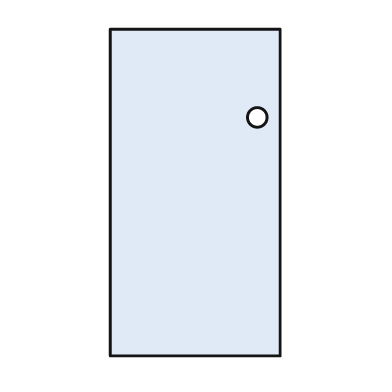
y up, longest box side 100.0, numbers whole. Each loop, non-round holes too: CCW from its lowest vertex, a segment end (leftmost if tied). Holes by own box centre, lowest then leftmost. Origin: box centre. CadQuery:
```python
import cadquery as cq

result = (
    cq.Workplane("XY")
    .moveTo(-26.0, -50.0)
    .lineTo(26.0, -50.0)
    .lineTo(26.0, 50.0)
    .lineTo(-26.0, 50.0)
    .close()
    .moveTo(19.0, 23.0)
    .circle(3.0)
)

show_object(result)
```